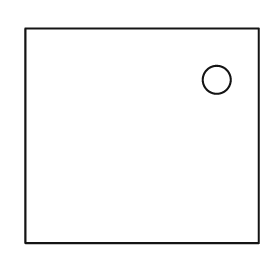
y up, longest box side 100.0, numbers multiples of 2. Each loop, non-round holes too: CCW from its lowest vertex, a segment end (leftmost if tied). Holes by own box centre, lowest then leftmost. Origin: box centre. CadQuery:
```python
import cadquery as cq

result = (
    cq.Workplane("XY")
    .moveTo(-50.0, -46.0)
    .lineTo(50.0, -46.0)
    .lineTo(50.0, 46.0)
    .lineTo(-50.0, 46.0)
    .close()
    .moveTo(32.0, 24.0)
    .circle(6.0)
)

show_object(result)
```